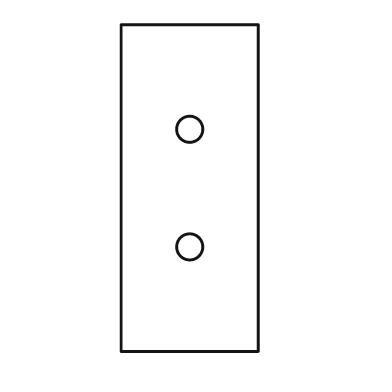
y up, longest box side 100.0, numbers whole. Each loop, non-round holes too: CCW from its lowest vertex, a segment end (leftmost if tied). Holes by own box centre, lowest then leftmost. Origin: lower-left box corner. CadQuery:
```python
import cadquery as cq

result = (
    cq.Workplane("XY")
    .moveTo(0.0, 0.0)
    .lineTo(42.0, 0.0)
    .lineTo(42.0, 100.0)
    .lineTo(0.0, 100.0)
    .close()
    .moveTo(21.0, 32.0)
    .circle(4.0)
    .moveTo(21.0, 68.0)
    .circle(4.0)
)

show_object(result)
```